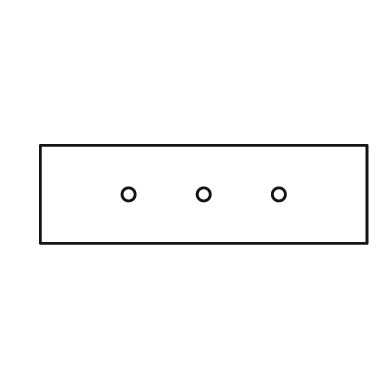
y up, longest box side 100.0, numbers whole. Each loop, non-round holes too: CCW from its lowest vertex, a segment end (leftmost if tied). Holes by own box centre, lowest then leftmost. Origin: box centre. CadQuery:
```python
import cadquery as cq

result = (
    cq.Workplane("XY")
    .moveTo(-50.0, -15.0)
    .lineTo(50.0, -15.0)
    .lineTo(50.0, 15.0)
    .lineTo(-50.0, 15.0)
    .close()
    .moveTo(-23.0, 0.0)
    .circle(2.0)
    .moveTo(0.0, 0.0)
    .circle(2.0)
    .moveTo(23.0, 0.0)
    .circle(2.0)
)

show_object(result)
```